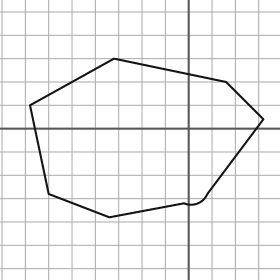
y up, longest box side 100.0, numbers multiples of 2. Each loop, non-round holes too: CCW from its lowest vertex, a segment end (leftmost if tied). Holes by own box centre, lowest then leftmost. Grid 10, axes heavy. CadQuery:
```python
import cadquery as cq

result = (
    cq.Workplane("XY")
    .moveTo(-34.0, -38.0)
    .lineTo(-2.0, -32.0)
    .threePointArc((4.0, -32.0), (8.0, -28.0))
    .lineTo(32.0, 4.0)
    .lineTo(16.0, 20.0)
    .lineTo(-32.0, 30.0)
    .lineTo(-68.0, 10.0)
    .lineTo(-60.0, -28.0)
    .close()
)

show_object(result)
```